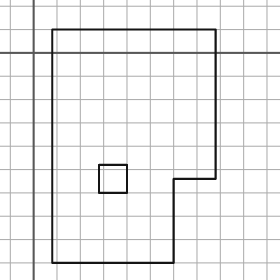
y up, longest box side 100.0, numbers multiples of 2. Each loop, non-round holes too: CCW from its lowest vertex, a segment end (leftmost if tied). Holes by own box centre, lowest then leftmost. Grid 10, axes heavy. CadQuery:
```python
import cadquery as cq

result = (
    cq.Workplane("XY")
    .moveTo(8.0, -90.0)
    .lineTo(60.0, -90.0)
    .lineTo(60.0, -54.0)
    .lineTo(78.0, -54.0)
    .lineTo(78.0, 10.0)
    .lineTo(8.0, 10.0)
    .close()
    .moveTo(28.0, -60.0)
    .lineTo(40.0, -60.0)
    .lineTo(40.0, -48.0)
    .lineTo(28.0, -48.0)
    .close()
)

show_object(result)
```